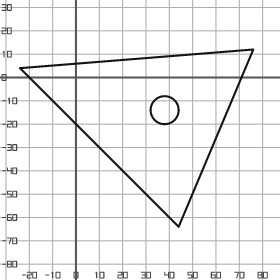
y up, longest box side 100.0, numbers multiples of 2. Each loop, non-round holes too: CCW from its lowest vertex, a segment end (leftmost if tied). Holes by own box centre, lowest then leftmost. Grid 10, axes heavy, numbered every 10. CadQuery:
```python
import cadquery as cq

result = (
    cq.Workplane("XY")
    .moveTo(44.0, -64.0)
    .lineTo(76.0, 12.0)
    .lineTo(-24.0, 4.0)
    .close()
    .moveTo(38.0, -14.0)
    .circle(6.0)
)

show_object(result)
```